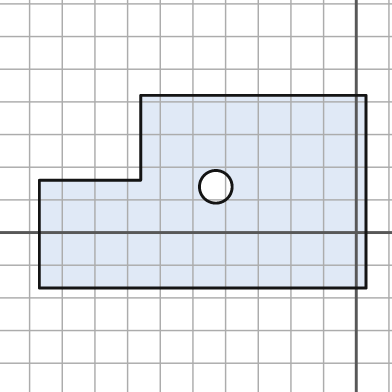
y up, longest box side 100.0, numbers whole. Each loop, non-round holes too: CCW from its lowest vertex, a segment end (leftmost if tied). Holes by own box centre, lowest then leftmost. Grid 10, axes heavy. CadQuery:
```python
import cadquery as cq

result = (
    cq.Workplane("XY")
    .moveTo(-97.0, -17.0)
    .lineTo(3.0, -17.0)
    .lineTo(3.0, 42.0)
    .lineTo(-66.0, 42.0)
    .lineTo(-66.0, 16.0)
    .lineTo(-97.0, 16.0)
    .close()
    .moveTo(-43.0, 14.0)
    .circle(5.0)
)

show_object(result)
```